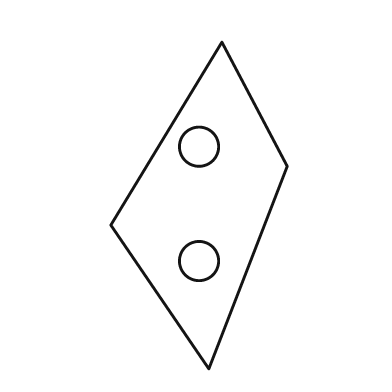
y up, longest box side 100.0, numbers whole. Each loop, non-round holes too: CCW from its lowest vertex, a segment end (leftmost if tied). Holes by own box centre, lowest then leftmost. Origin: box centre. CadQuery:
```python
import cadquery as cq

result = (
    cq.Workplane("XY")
    .moveTo(3.0, -50.0)
    .lineTo(27.0, 12.0)
    .lineTo(7.0, 50.0)
    .lineTo(-27.0, -6.0)
    .close()
    .moveTo(0.0, -17.0)
    .circle(6.0)
    .moveTo(0.0, 18.0)
    .circle(6.0)
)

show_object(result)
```